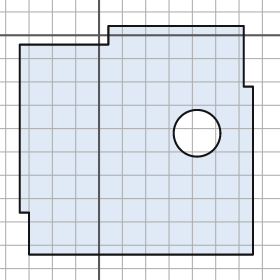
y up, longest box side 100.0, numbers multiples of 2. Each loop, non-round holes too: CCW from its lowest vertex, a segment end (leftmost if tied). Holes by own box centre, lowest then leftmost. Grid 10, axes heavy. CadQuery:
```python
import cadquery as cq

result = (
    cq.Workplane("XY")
    .moveTo(-30.0, -94.0)
    .lineTo(66.0, -94.0)
    .lineTo(66.0, -22.0)
    .lineTo(62.0, -22.0)
    .lineTo(62.0, 4.0)
    .lineTo(4.0, 4.0)
    .lineTo(4.0, -4.0)
    .lineTo(-34.0, -4.0)
    .lineTo(-34.0, -76.0)
    .lineTo(-30.0, -76.0)
    .close()
    .moveTo(42.0, -42.0)
    .circle(10.0)
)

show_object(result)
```